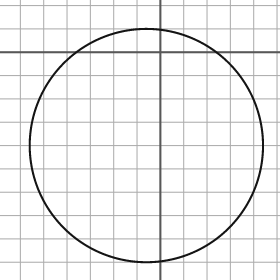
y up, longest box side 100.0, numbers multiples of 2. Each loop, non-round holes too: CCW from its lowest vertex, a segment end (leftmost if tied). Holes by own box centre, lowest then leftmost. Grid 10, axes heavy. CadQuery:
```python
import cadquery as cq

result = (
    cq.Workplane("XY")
    .moveTo(-6.0, -40.0)
    .circle(50.0)
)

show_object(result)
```